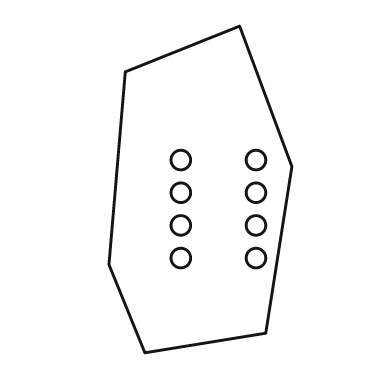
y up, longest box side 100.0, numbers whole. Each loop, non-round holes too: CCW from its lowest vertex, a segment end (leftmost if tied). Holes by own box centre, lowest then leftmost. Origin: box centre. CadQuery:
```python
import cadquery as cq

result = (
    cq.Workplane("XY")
    .moveTo(-17.0, -50.0)
    .lineTo(20.0, -44.0)
    .lineTo(28.0, 7.0)
    .lineTo(12.0, 50.0)
    .lineTo(-23.0, 36.0)
    .lineTo(-28.0, -23.0)
    .close()
    .moveTo(-6.0, -21.0)
    .circle(3.0)
    .moveTo(17.0, -21.0)
    .circle(3.0)
    .moveTo(-6.0, -11.0)
    .circle(3.0)
    .moveTo(17.0, -11.0)
    .circle(3.0)
    .moveTo(-6.0, -1.0)
    .circle(3.0)
    .moveTo(17.0, -1.0)
    .circle(3.0)
    .moveTo(-6.0, 9.0)
    .circle(3.0)
    .moveTo(17.0, 9.0)
    .circle(3.0)
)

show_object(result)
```